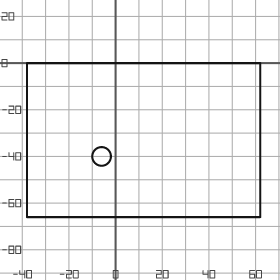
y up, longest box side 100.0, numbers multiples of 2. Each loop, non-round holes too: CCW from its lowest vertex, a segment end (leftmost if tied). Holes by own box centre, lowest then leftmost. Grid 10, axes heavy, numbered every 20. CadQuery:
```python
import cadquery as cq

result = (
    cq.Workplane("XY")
    .moveTo(-38.0, -66.0)
    .lineTo(62.0, -66.0)
    .lineTo(62.0, 0.0)
    .lineTo(-38.0, 0.0)
    .close()
    .moveTo(-6.0, -40.0)
    .circle(4.0)
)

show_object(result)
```